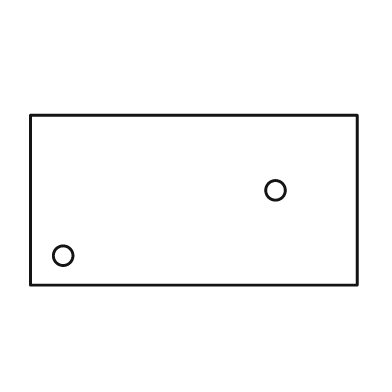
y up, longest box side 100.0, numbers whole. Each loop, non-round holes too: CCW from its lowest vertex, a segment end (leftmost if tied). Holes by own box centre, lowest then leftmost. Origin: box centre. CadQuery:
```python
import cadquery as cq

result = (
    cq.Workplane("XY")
    .moveTo(-50.0, -26.0)
    .lineTo(50.0, -26.0)
    .lineTo(50.0, 26.0)
    .lineTo(-50.0, 26.0)
    .close()
    .moveTo(-40.0, -17.0)
    .circle(3.0)
    .moveTo(25.0, 3.0)
    .circle(3.0)
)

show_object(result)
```